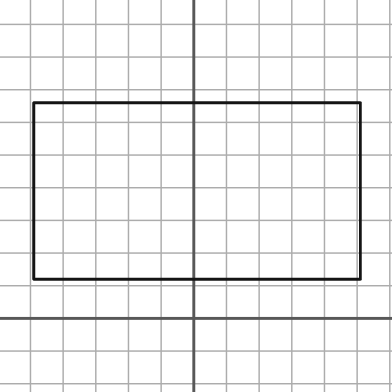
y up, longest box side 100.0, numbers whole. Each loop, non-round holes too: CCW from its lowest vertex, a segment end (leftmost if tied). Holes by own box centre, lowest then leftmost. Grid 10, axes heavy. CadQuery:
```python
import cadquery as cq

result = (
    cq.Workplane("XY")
    .moveTo(-49.0, 12.0)
    .lineTo(51.0, 12.0)
    .lineTo(51.0, 66.0)
    .lineTo(-49.0, 66.0)
    .close()
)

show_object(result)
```